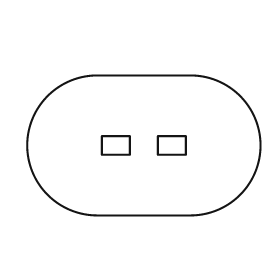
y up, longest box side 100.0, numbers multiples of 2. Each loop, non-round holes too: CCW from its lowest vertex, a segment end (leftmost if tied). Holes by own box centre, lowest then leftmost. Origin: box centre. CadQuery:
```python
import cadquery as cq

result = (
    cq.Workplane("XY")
    .moveTo(-20.0, -30.0)
    .lineTo(20.0, -30.0)
    .threePointArc((50.0, 0.0), (20.0, 30.0))
    .lineTo(-20.0, 30.0)
    .threePointArc((-50.0, 0.0), (-20.0, -30.0))
    .close()
    .moveTo(-18.0, -4.0)
    .lineTo(-6.0, -4.0)
    .lineTo(-6.0, 4.0)
    .lineTo(-18.0, 4.0)
    .close()
    .moveTo(6.0, -4.0)
    .lineTo(18.0, -4.0)
    .lineTo(18.0, 4.0)
    .lineTo(6.0, 4.0)
    .close()
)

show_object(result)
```